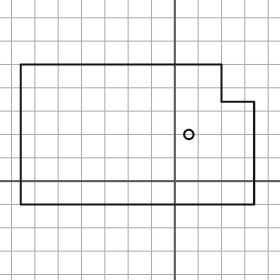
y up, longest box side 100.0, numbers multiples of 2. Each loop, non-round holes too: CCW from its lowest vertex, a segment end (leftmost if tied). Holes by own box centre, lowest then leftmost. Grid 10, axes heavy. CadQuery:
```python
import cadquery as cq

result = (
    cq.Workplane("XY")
    .moveTo(-66.0, -10.0)
    .lineTo(34.0, -10.0)
    .lineTo(34.0, 34.0)
    .lineTo(20.0, 34.0)
    .lineTo(20.0, 50.0)
    .lineTo(-66.0, 50.0)
    .close()
    .moveTo(6.0, 20.0)
    .circle(2.0)
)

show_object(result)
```